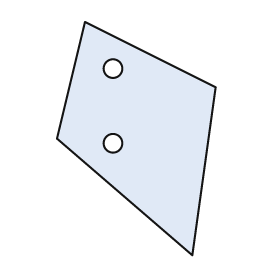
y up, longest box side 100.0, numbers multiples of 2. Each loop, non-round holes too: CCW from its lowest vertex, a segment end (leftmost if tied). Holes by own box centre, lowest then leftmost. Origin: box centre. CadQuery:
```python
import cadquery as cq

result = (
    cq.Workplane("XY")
    .moveTo(24.0, -50.0)
    .lineTo(34.0, 22.0)
    .lineTo(-22.0, 50.0)
    .lineTo(-34.0, 0.0)
    .close()
    .moveTo(-10.0, -2.0)
    .circle(4.0)
    .moveTo(-10.0, 30.0)
    .circle(4.0)
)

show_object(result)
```